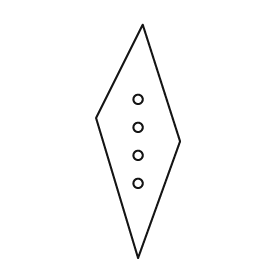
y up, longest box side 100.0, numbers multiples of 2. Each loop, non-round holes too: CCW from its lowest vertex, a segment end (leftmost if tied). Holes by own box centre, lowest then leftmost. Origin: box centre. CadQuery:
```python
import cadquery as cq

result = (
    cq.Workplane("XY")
    .moveTo(0.0, -50.0)
    .lineTo(18.0, 0.0)
    .lineTo(2.0, 50.0)
    .lineTo(-18.0, 10.0)
    .close()
    .moveTo(0.0, -18.0)
    .circle(2.0)
    .moveTo(0.0, -6.0)
    .circle(2.0)
    .moveTo(0.0, 6.0)
    .circle(2.0)
    .moveTo(0.0, 18.0)
    .circle(2.0)
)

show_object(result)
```